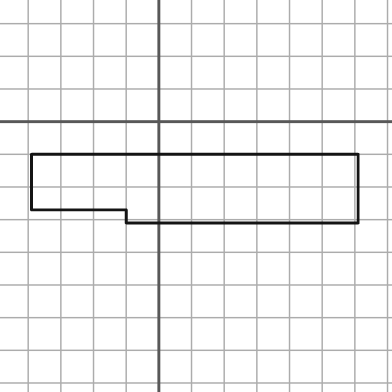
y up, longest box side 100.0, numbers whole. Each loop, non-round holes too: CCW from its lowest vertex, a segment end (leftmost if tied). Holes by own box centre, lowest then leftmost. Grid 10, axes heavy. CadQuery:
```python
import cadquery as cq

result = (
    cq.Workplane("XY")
    .moveTo(-10.0, -31.0)
    .lineTo(61.0, -31.0)
    .lineTo(61.0, -10.0)
    .lineTo(-39.0, -10.0)
    .lineTo(-39.0, -27.0)
    .lineTo(-10.0, -27.0)
    .close()
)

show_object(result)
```